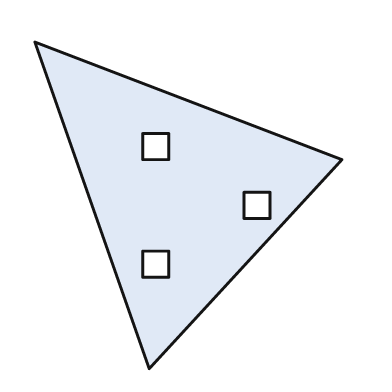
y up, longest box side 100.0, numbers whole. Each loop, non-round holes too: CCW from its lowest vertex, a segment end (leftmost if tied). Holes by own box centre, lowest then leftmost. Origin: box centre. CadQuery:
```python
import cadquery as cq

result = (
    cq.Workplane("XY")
    .moveTo(-12.0, -50.0)
    .lineTo(47.0, 14.0)
    .lineTo(-47.0, 50.0)
    .close()
    .moveTo(-14.0, -22.0)
    .lineTo(-6.0, -22.0)
    .lineTo(-6.0, -14.0)
    .lineTo(-14.0, -14.0)
    .close()
    .moveTo(17.0, -4.0)
    .lineTo(25.0, -4.0)
    .lineTo(25.0, 4.0)
    .lineTo(17.0, 4.0)
    .close()
    .moveTo(-14.0, 14.0)
    .lineTo(-6.0, 14.0)
    .lineTo(-6.0, 22.0)
    .lineTo(-14.0, 22.0)
    .close()
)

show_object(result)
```